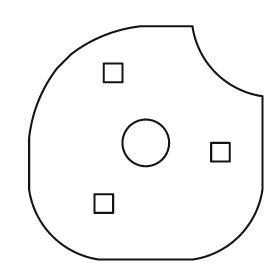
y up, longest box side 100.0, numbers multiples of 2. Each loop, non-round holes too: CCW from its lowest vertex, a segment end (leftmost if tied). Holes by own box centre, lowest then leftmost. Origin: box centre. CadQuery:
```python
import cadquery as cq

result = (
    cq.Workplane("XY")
    .moveTo(-20.0, -50.0)
    .lineTo(20.0, -50.0)
    .threePointArc((40.0, -40.0), (50.0, -20.0))
    .lineTo(50.0, 20.0)
    .threePointArc((30.0, 30.0), (20.0, 50.0))
    .lineTo(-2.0, 50.0)
    .threePointArc((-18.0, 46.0), (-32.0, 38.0))
    .lineTo(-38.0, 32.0)
    .threePointArc((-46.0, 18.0), (-50.0, 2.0))
    .lineTo(-50.0, -20.0)
    .threePointArc((-40.0, -40.0), (-20.0, -50.0))
    .close()
    .moveTo(-22.0, -30.0)
    .lineTo(-14.0, -30.0)
    .lineTo(-14.0, -22.0)
    .lineTo(-22.0, -22.0)
    .close()
    .moveTo(28.0, -8.0)
    .lineTo(36.0, -8.0)
    .lineTo(36.0, 0.0)
    .lineTo(28.0, 0.0)
    .close()
    .moveTo(0.0, 0.0)
    .circle(10.0)
    .moveTo(-18.0, 26.0)
    .lineTo(-10.0, 26.0)
    .lineTo(-10.0, 34.0)
    .lineTo(-18.0, 34.0)
    .close()
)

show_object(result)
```